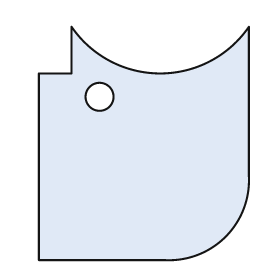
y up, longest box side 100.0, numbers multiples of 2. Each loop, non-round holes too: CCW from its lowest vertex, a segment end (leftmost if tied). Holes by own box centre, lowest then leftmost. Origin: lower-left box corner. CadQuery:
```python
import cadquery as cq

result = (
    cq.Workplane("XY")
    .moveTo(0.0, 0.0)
    .lineTo(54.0, 0.0)
    .threePointArc((80.0, 10.0), (90.0, 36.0))
    .lineTo(90.0, 100.0)
    .threePointArc((52.0, 80.0), (14.0, 100.0))
    .lineTo(14.0, 80.0)
    .lineTo(0.0, 80.0)
    .close()
    .moveTo(26.0, 70.0)
    .circle(6.0)
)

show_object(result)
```